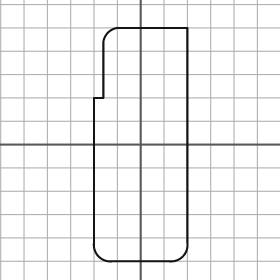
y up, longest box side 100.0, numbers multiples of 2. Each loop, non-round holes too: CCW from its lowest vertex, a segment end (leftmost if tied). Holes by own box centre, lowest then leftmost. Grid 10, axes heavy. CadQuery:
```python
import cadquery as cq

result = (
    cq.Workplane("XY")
    .moveTo(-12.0, -50.0)
    .lineTo(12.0, -50.0)
    .threePointArc((18.0, -48.0), (20.0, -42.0))
    .lineTo(20.0, 50.0)
    .lineTo(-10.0, 50.0)
    .threePointArc((-14.0, 48.0), (-16.0, 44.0))
    .lineTo(-16.0, 20.0)
    .lineTo(-20.0, 20.0)
    .lineTo(-20.0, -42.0)
    .threePointArc((-18.0, -48.0), (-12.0, -50.0))
    .close()
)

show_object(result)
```